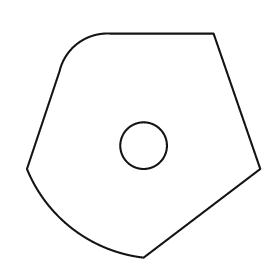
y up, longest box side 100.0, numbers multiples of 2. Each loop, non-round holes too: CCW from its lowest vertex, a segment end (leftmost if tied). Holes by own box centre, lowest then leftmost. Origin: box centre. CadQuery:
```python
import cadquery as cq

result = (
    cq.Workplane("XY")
    .moveTo(0.0, -48.0)
    .lineTo(50.0, -10.0)
    .lineTo(30.0, 48.0)
    .lineTo(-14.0, 48.0)
    .threePointArc((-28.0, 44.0), (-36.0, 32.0))
    .lineTo(-50.0, -10.0)
    .threePointArc((-30.0, -36.0), (0.0, -48.0))
    .close()
    .moveTo(0.0, 0.0)
    .circle(10.0)
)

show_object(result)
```